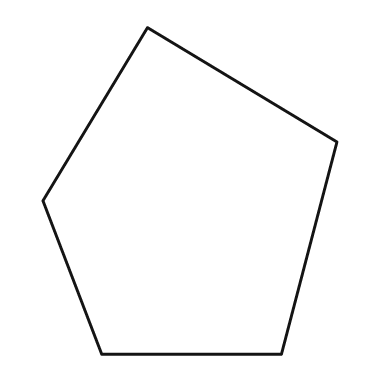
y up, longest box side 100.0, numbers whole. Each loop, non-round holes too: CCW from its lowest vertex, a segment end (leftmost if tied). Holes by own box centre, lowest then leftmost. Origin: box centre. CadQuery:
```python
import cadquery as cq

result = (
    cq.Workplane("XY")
    .moveTo(-27.0, -50.0)
    .lineTo(28.0, -50.0)
    .lineTo(45.0, 15.0)
    .lineTo(-13.0, 50.0)
    .lineTo(-45.0, -3.0)
    .close()
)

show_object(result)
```